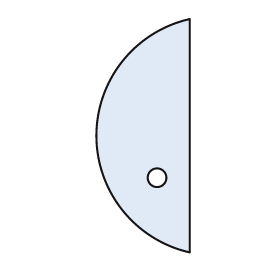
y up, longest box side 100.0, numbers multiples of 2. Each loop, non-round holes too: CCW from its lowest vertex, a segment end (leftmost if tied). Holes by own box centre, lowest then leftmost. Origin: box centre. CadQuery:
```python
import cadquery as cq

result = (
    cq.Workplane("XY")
    .moveTo(20.0, -50.0)
    .lineTo(20.0, 50.0)
    .threePointArc((-20.0, 0.0), (20.0, -50.0))
    .close()
    .moveTo(6.0, -18.0)
    .circle(4.0)
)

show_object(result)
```